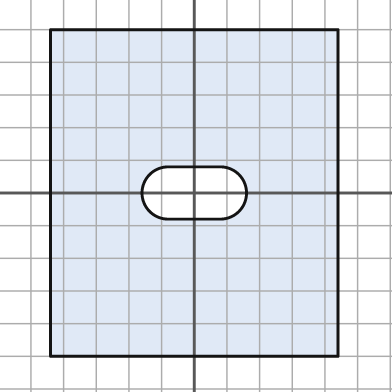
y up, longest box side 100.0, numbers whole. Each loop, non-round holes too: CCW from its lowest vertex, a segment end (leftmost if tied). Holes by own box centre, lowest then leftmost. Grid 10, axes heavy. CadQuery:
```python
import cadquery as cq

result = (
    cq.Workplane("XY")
    .moveTo(-44.0, -50.0)
    .lineTo(44.0, -50.0)
    .lineTo(44.0, 50.0)
    .lineTo(-44.0, 50.0)
    .close()
    .moveTo(-8.0, -8.0)
    .lineTo(8.0, -8.0)
    .threePointArc((16.0, 0.0), (8.0, 8.0))
    .lineTo(-8.0, 8.0)
    .threePointArc((-16.0, 0.0), (-8.0, -8.0))
    .close()
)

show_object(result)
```